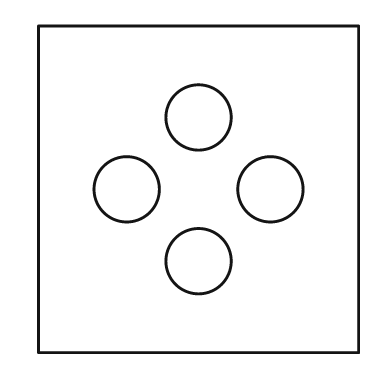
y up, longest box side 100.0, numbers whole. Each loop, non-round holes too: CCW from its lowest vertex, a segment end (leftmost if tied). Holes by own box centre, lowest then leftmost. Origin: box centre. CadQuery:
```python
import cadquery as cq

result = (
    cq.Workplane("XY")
    .moveTo(-49.0, -50.0)
    .lineTo(49.0, -50.0)
    .lineTo(49.0, 50.0)
    .lineTo(-49.0, 50.0)
    .close()
    .moveTo(0.0, -22.0)
    .circle(10.0)
    .moveTo(-22.0, 0.0)
    .circle(10.0)
    .moveTo(22.0, 0.0)
    .circle(10.0)
    .moveTo(0.0, 22.0)
    .circle(10.0)
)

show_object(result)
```